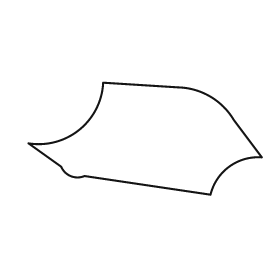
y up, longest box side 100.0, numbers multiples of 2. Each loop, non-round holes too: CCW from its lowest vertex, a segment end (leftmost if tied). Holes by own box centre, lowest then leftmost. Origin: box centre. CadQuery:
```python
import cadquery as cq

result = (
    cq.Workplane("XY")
    .moveTo(28.0, -24.0)
    .threePointArc((36.0, -12.0), (50.0, -8.0))
    .lineTo(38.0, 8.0)
    .threePointArc((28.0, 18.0), (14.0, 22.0))
    .lineTo(-18.0, 24.0)
    .threePointArc((-28.0, 4.0), (-50.0, -2.0))
    .lineTo(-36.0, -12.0)
    .threePointArc((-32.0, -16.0), (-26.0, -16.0))
    .close()
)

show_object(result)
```